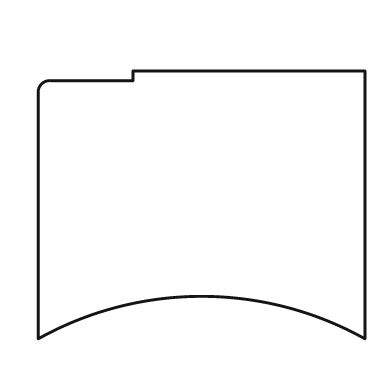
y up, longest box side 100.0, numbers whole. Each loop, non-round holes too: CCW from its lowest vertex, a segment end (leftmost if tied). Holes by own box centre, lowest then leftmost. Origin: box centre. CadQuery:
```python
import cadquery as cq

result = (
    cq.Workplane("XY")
    .moveTo(-50.0, -41.0)
    .threePointArc((0.0, -28.0), (50.0, -41.0))
    .lineTo(50.0, 41.0)
    .lineTo(-21.0, 41.0)
    .lineTo(-21.0, 38.0)
    .lineTo(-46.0, 38.0)
    .threePointArc((-49.0, 37.0), (-50.0, 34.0))
    .close()
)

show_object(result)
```